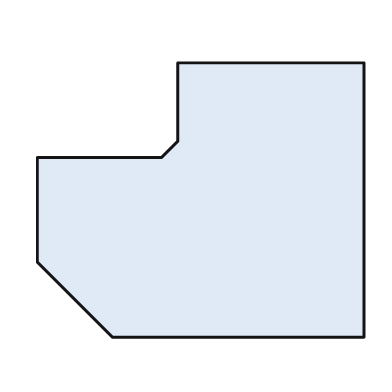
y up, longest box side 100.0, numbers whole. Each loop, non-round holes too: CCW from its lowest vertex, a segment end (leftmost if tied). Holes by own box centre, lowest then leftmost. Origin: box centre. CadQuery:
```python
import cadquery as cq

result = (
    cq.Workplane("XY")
    .moveTo(-27.0, -42.0)
    .lineTo(50.0, -42.0)
    .lineTo(50.0, 42.0)
    .lineTo(-7.0, 42.0)
    .lineTo(-7.0, 18.0)
    .lineTo(-12.0, 13.0)
    .lineTo(-50.0, 13.0)
    .lineTo(-50.0, -19.0)
    .close()
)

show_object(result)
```